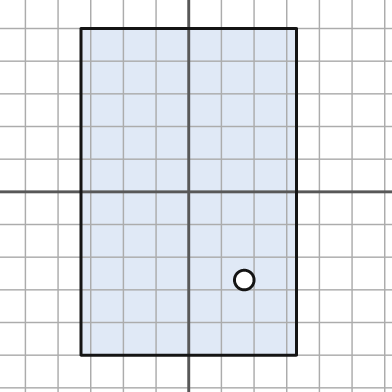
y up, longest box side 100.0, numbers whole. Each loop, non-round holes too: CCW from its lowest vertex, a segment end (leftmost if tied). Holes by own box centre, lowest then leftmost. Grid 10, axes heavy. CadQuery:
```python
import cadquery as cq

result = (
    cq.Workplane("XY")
    .moveTo(-33.0, -50.0)
    .lineTo(33.0, -50.0)
    .lineTo(33.0, 50.0)
    .lineTo(-33.0, 50.0)
    .close()
    .moveTo(17.0, -27.0)
    .circle(3.0)
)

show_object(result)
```